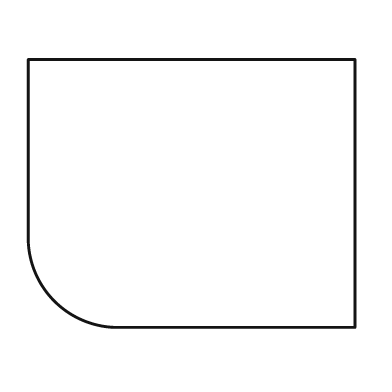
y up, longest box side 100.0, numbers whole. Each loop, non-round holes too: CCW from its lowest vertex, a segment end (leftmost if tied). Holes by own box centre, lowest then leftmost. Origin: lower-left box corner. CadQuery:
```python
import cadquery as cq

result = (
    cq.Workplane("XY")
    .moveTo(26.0, 0.0)
    .lineTo(100.0, 0.0)
    .lineTo(100.0, 82.0)
    .lineTo(0.0, 82.0)
    .lineTo(0.0, 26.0)
    .threePointArc((8.0, 8.0), (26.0, 0.0))
    .close()
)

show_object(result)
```